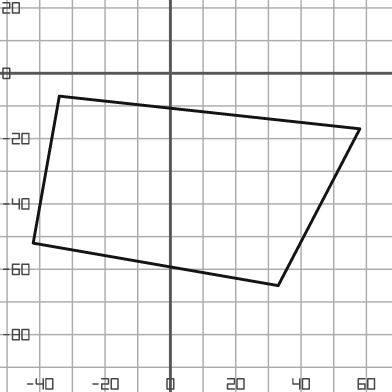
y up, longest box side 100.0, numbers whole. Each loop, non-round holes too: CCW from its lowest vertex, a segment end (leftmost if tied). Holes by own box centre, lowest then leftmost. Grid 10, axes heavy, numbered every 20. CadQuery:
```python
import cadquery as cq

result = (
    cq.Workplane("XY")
    .moveTo(33.0, -65.0)
    .lineTo(58.0, -17.0)
    .lineTo(-34.0, -7.0)
    .lineTo(-42.0, -52.0)
    .close()
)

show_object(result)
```